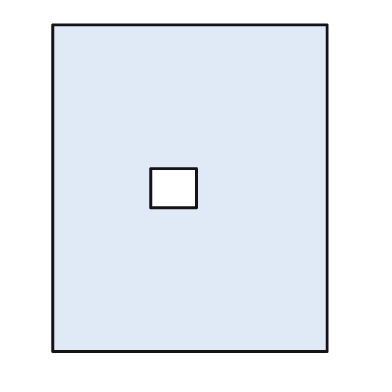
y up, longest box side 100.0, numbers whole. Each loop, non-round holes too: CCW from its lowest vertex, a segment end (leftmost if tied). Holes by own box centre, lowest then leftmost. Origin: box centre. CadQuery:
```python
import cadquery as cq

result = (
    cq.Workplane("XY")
    .moveTo(-42.0, -50.0)
    .lineTo(42.0, -50.0)
    .lineTo(42.0, 50.0)
    .lineTo(-42.0, 50.0)
    .close()
    .moveTo(-12.0, -6.0)
    .lineTo(2.0, -6.0)
    .lineTo(2.0, 6.0)
    .lineTo(-12.0, 6.0)
    .close()
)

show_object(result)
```